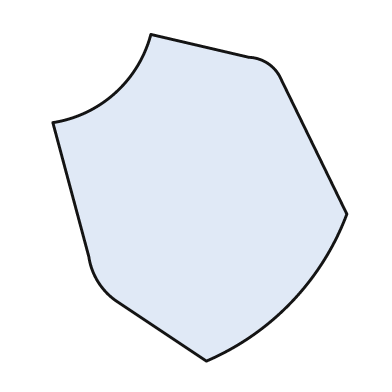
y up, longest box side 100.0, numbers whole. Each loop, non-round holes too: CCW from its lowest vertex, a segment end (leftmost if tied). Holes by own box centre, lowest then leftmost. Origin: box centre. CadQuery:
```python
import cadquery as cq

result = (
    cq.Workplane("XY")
    .moveTo(2.0, -50.0)
    .threePointArc((28.0, -32.0), (45.0, -5.0))
    .lineTo(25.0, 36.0)
    .threePointArc((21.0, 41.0), (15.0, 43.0))
    .lineTo(-15.0, 50.0)
    .threePointArc((-26.0, 32.0), (-45.0, 23.0))
    .lineTo(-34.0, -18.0)
    .threePointArc((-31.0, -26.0), (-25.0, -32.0))
    .close()
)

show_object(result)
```